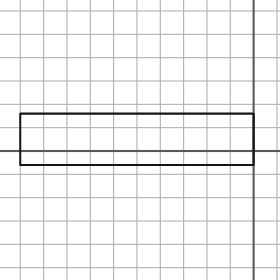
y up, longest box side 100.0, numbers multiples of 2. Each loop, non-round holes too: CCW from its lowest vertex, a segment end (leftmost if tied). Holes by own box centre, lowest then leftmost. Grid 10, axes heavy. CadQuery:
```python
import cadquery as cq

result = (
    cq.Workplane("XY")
    .moveTo(-100.0, -6.0)
    .lineTo(0.0, -6.0)
    .lineTo(0.0, 16.0)
    .lineTo(-100.0, 16.0)
    .close()
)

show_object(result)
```